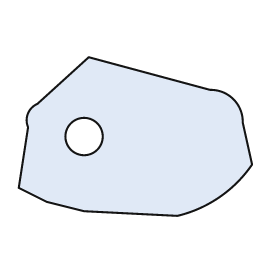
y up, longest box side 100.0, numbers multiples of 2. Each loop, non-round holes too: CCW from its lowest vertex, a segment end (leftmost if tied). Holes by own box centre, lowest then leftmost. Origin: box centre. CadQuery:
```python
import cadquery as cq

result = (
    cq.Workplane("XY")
    .moveTo(18.0, -34.0)
    .threePointArc((36.0, -26.0), (50.0, -12.0))
    .lineTo(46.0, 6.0)
    .threePointArc((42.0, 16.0), (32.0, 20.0))
    .lineTo(-20.0, 34.0)
    .lineTo(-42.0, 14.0)
    .threePointArc((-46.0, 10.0), (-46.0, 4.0))
    .lineTo(-50.0, -22.0)
    .lineTo(-38.0, -28.0)
    .lineTo(-22.0, -32.0)
    .close()
    .moveTo(-22.0, 0.0)
    .circle(8.0)
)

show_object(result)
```